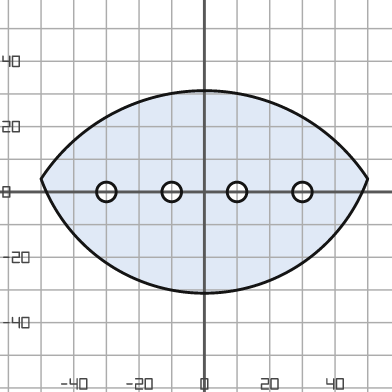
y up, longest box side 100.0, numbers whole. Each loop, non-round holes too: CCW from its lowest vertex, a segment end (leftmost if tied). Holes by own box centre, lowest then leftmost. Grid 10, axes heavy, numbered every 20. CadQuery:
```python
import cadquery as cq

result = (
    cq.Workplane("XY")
    .moveTo(-50.0, 4.0)
    .threePointArc((0.0, -31.0), (50.0, 4.0))
    .threePointArc((0.0, 31.0), (-50.0, 4.0))
    .close()
    .moveTo(-30.0, 0.0)
    .circle(3.0)
    .moveTo(-10.0, 0.0)
    .circle(3.0)
    .moveTo(10.0, 0.0)
    .circle(3.0)
    .moveTo(30.0, 0.0)
    .circle(3.0)
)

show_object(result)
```